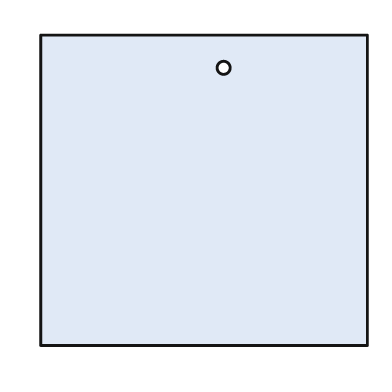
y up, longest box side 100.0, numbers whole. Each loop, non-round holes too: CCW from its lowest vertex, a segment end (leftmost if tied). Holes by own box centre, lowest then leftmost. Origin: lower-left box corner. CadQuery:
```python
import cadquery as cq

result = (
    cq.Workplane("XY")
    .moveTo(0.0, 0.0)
    .lineTo(100.0, 0.0)
    .lineTo(100.0, 95.0)
    .lineTo(0.0, 95.0)
    .close()
    .moveTo(56.0, 85.0)
    .circle(2.0)
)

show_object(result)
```